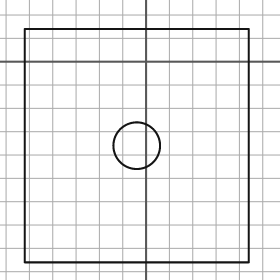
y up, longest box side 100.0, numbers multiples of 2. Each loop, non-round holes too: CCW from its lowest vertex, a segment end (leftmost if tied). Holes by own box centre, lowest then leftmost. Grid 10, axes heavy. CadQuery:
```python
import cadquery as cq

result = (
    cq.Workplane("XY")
    .moveTo(-52.0, -86.0)
    .lineTo(44.0, -86.0)
    .lineTo(44.0, 14.0)
    .lineTo(-52.0, 14.0)
    .close()
    .moveTo(-4.0, -36.0)
    .circle(10.0)
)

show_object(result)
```